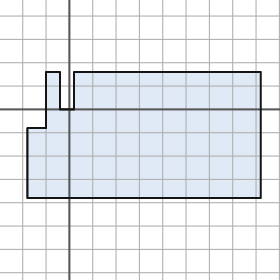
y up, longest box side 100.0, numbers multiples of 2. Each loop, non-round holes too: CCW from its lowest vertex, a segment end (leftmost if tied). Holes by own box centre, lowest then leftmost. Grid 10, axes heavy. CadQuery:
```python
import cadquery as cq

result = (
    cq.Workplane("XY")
    .moveTo(-18.0, -38.0)
    .lineTo(82.0, -38.0)
    .lineTo(82.0, 16.0)
    .lineTo(2.0, 16.0)
    .lineTo(2.0, 0.0)
    .lineTo(-4.0, 0.0)
    .lineTo(-4.0, 16.0)
    .lineTo(-10.0, 16.0)
    .lineTo(-10.0, -8.0)
    .lineTo(-18.0, -8.0)
    .close()
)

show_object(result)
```